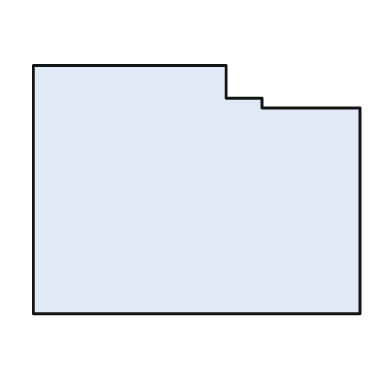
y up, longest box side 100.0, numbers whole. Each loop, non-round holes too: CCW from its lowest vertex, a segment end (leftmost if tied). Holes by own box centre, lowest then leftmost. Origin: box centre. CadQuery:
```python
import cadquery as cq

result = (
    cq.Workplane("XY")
    .moveTo(-50.0, -38.0)
    .lineTo(50.0, -38.0)
    .lineTo(50.0, 25.0)
    .lineTo(20.0, 25.0)
    .lineTo(20.0, 28.0)
    .lineTo(9.0, 28.0)
    .lineTo(9.0, 38.0)
    .lineTo(-50.0, 38.0)
    .close()
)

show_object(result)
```